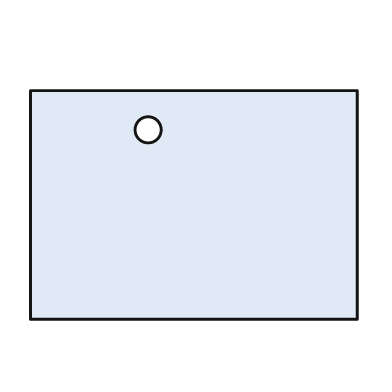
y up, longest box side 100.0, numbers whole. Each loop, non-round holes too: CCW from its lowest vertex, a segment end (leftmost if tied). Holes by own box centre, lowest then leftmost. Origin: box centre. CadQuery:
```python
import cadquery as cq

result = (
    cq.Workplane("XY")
    .moveTo(-50.0, -35.0)
    .lineTo(50.0, -35.0)
    .lineTo(50.0, 35.0)
    .lineTo(-50.0, 35.0)
    .close()
    .moveTo(-14.0, 23.0)
    .circle(4.0)
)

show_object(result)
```